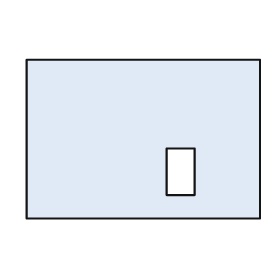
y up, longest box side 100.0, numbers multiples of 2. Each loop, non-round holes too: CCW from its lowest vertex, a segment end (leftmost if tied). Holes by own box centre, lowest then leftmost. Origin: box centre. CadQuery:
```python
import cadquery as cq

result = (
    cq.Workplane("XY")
    .moveTo(-50.0, -34.0)
    .lineTo(50.0, -34.0)
    .lineTo(50.0, 34.0)
    .lineTo(-50.0, 34.0)
    .close()
    .moveTo(10.0, -24.0)
    .lineTo(22.0, -24.0)
    .lineTo(22.0, -4.0)
    .lineTo(10.0, -4.0)
    .close()
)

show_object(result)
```